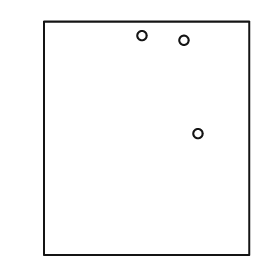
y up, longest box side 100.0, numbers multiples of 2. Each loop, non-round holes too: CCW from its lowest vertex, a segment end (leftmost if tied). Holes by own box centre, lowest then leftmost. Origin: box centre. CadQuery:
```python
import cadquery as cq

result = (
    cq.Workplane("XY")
    .moveTo(-44.0, -50.0)
    .lineTo(44.0, -50.0)
    .lineTo(44.0, 50.0)
    .lineTo(-44.0, 50.0)
    .close()
    .moveTo(22.0, 2.0)
    .circle(2.0)
    .moveTo(16.0, 42.0)
    .circle(2.0)
    .moveTo(-2.0, 44.0)
    .circle(2.0)
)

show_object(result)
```